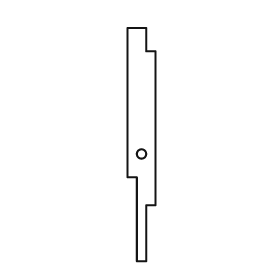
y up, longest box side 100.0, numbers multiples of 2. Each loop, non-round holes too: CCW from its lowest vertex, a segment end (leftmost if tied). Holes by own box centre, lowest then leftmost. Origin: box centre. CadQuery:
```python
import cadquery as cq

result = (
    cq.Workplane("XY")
    .moveTo(-2.0, -50.0)
    .lineTo(2.0, -50.0)
    .lineTo(2.0, -26.0)
    .lineTo(6.0, -26.0)
    .lineTo(6.0, 40.0)
    .lineTo(2.0, 40.0)
    .lineTo(2.0, 50.0)
    .lineTo(-6.0, 50.0)
    .lineTo(-6.0, -14.0)
    .lineTo(-2.0, -14.0)
    .close()
    .moveTo(0.0, -4.0)
    .circle(2.0)
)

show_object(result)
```